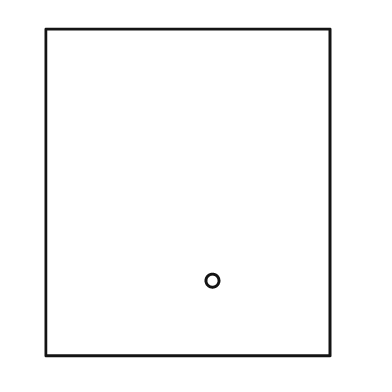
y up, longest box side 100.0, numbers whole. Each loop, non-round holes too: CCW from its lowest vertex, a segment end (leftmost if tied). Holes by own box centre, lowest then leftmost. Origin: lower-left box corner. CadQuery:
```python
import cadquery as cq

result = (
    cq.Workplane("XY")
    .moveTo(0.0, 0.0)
    .lineTo(87.0, 0.0)
    .lineTo(87.0, 100.0)
    .lineTo(0.0, 100.0)
    .close()
    .moveTo(51.0, 23.0)
    .circle(2.0)
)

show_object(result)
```